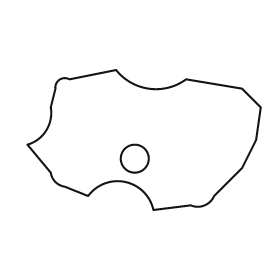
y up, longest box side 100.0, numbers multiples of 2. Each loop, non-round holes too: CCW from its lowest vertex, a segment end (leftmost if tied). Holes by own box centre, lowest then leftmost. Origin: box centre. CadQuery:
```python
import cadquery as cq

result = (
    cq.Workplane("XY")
    .moveTo(4.0, -30.0)
    .lineTo(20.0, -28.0)
    .threePointArc((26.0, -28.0), (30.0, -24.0))
    .lineTo(42.0, -12.0)
    .lineTo(48.0, 0.0)
    .lineTo(50.0, 14.0)
    .lineTo(42.0, 22.0)
    .lineTo(18.0, 26.0)
    .threePointArc((2.0, 22.0), (-12.0, 30.0))
    .lineTo(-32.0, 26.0)
    .threePointArc((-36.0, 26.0), (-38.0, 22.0))
    .lineTo(-40.0, 14.0)
    .threePointArc((-42.0, 4.0), (-50.0, -2.0))
    .lineTo(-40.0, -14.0)
    .threePointArc((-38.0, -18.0), (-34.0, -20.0))
    .lineTo(-24.0, -24.0)
    .threePointArc((-8.0, -18.0), (4.0, -30.0))
    .close()
    .moveTo(-4.0, -8.0)
    .circle(6.0)
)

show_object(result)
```